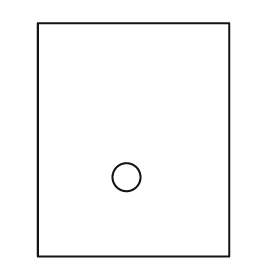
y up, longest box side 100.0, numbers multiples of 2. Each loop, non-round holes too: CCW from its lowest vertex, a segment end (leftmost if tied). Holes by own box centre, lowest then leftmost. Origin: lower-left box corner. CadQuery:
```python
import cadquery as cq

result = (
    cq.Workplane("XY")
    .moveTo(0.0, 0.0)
    .lineTo(82.0, 0.0)
    .lineTo(82.0, 100.0)
    .lineTo(0.0, 100.0)
    .close()
    .moveTo(38.0, 34.0)
    .circle(6.0)
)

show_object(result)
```